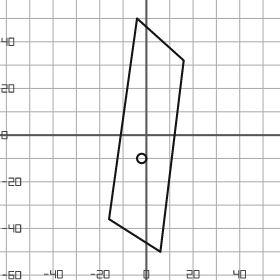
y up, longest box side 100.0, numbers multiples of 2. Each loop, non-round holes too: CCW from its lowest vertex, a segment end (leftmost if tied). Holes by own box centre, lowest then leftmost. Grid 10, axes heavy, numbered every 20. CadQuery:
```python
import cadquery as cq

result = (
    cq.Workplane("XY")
    .moveTo(6.0, -50.0)
    .lineTo(16.0, 32.0)
    .lineTo(-4.0, 50.0)
    .lineTo(-16.0, -36.0)
    .close()
    .moveTo(-2.0, -10.0)
    .circle(2.0)
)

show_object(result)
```